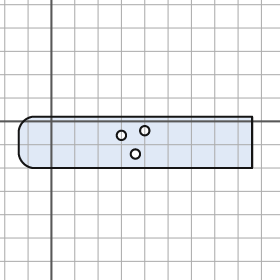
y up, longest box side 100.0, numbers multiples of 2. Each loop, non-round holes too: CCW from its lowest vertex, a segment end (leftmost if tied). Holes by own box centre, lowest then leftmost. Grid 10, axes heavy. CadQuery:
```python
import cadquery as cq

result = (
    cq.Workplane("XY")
    .moveTo(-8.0, -20.0)
    .lineTo(86.0, -20.0)
    .lineTo(86.0, 2.0)
    .lineTo(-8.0, 2.0)
    .threePointArc((-12.0, 0.0), (-14.0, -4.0))
    .lineTo(-14.0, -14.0)
    .threePointArc((-12.0, -18.0), (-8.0, -20.0))
    .close()
    .moveTo(36.0, -14.0)
    .circle(2.0)
    .moveTo(30.0, -6.0)
    .circle(2.0)
    .moveTo(40.0, -4.0)
    .circle(2.0)
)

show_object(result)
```